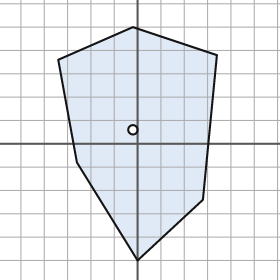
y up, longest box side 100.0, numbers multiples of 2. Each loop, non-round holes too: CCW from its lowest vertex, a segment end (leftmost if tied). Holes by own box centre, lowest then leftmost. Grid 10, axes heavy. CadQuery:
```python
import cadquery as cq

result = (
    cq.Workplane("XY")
    .moveTo(0.0, -50.0)
    .lineTo(28.0, -24.0)
    .lineTo(34.0, 38.0)
    .lineTo(-2.0, 50.0)
    .lineTo(-34.0, 36.0)
    .lineTo(-26.0, -8.0)
    .close()
    .moveTo(-2.0, 6.0)
    .circle(2.0)
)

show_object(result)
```